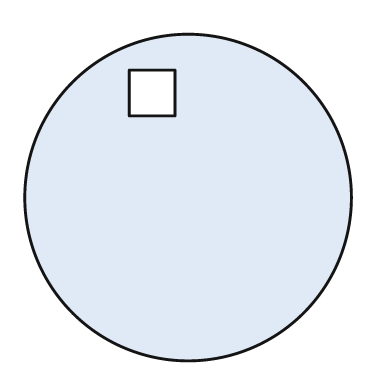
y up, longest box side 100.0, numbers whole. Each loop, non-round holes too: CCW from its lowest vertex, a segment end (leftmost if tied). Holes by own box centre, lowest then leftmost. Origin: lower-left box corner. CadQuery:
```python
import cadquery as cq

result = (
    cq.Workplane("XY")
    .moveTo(50.0, 50.0)
    .circle(50.0)
    .moveTo(32.0, 75.0)
    .lineTo(46.0, 75.0)
    .lineTo(46.0, 89.0)
    .lineTo(32.0, 89.0)
    .close()
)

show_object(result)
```